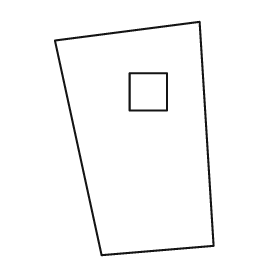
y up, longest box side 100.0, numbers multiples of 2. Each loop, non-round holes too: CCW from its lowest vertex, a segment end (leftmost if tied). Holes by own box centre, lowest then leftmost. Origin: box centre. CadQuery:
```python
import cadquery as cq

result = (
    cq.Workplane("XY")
    .moveTo(-14.0, -50.0)
    .lineTo(34.0, -46.0)
    .lineTo(28.0, 50.0)
    .lineTo(-34.0, 42.0)
    .close()
    .moveTo(-2.0, 12.0)
    .lineTo(14.0, 12.0)
    .lineTo(14.0, 28.0)
    .lineTo(-2.0, 28.0)
    .close()
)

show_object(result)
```